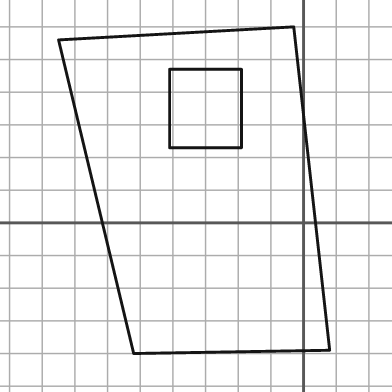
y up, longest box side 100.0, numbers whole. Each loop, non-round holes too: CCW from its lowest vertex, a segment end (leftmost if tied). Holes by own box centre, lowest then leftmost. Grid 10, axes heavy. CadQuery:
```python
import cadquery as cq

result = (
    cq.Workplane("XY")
    .moveTo(-52.0, -40.0)
    .lineTo(8.0, -39.0)
    .lineTo(-3.0, 60.0)
    .lineTo(-75.0, 56.0)
    .close()
    .moveTo(-41.0, 23.0)
    .lineTo(-19.0, 23.0)
    .lineTo(-19.0, 47.0)
    .lineTo(-41.0, 47.0)
    .close()
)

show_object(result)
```